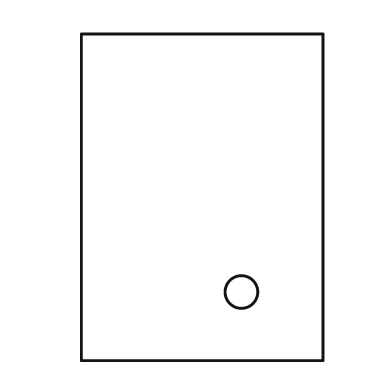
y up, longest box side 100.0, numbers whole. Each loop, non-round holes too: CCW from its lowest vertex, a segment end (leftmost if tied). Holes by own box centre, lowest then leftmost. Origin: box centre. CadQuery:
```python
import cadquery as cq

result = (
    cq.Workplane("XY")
    .moveTo(-37.0, -50.0)
    .lineTo(37.0, -50.0)
    .lineTo(37.0, 50.0)
    .lineTo(-37.0, 50.0)
    .close()
    .moveTo(12.0, -29.0)
    .circle(5.0)
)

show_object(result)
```